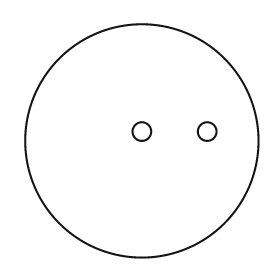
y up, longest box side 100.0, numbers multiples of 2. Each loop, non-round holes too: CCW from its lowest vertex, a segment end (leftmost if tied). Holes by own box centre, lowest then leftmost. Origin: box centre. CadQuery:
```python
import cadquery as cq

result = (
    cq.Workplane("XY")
    .moveTo(0.0, 0.0)
    .circle(50.0)
    .moveTo(0.0, 4.0)
    .circle(4.0)
    .moveTo(28.0, 4.0)
    .circle(4.0)
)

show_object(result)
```